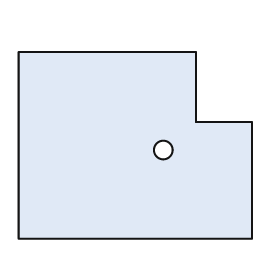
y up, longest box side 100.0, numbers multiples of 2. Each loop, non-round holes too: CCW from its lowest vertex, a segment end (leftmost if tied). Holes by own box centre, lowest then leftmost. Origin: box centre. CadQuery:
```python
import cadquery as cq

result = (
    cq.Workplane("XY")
    .moveTo(-50.0, -40.0)
    .lineTo(50.0, -40.0)
    .lineTo(50.0, 10.0)
    .lineTo(26.0, 10.0)
    .lineTo(26.0, 40.0)
    .lineTo(-50.0, 40.0)
    .close()
    .moveTo(12.0, -2.0)
    .circle(4.0)
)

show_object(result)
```